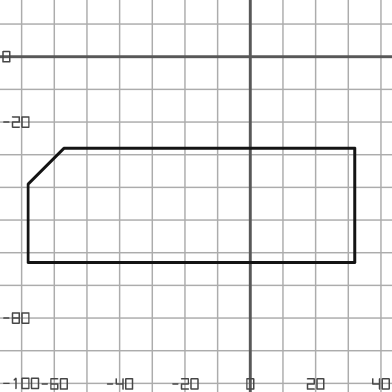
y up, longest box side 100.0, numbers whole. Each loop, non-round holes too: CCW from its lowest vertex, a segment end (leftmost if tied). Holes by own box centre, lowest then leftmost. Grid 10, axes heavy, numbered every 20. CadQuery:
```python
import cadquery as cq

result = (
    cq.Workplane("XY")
    .moveTo(-68.0, -63.0)
    .lineTo(32.0, -63.0)
    .lineTo(32.0, -28.0)
    .lineTo(-57.0, -28.0)
    .lineTo(-68.0, -39.0)
    .close()
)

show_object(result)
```